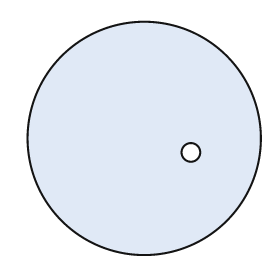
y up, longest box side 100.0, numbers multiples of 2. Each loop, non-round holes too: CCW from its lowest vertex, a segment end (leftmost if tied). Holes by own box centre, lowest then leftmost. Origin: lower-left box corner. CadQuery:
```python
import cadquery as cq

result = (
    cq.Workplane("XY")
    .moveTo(50.0, 50.0)
    .circle(50.0)
    .moveTo(70.0, 44.0)
    .circle(4.0)
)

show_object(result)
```